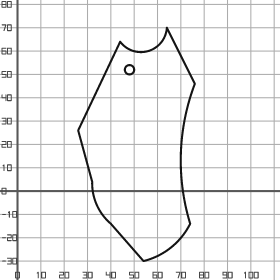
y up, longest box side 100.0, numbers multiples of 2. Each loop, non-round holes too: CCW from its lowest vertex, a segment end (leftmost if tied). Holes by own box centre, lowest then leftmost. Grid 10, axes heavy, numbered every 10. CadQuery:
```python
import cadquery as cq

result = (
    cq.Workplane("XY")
    .moveTo(54.0, -30.0)
    .threePointArc((66.0, -24.0), (74.0, -14.0))
    .threePointArc((70.0, 16.0), (76.0, 46.0))
    .lineTo(64.0, 70.0)
    .threePointArc((56.0, 60.0), (44.0, 64.0))
    .lineTo(26.0, 26.0)
    .lineTo(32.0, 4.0)
    .threePointArc((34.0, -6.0), (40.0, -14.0))
    .close()
    .moveTo(48.0, 52.0)
    .circle(2.0)
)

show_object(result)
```